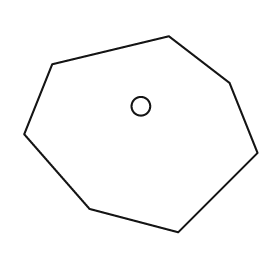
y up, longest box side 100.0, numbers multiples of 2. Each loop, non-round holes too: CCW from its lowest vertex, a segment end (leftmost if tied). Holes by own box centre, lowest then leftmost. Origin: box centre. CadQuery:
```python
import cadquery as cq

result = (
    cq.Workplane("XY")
    .moveTo(16.0, -42.0)
    .lineTo(50.0, -8.0)
    .lineTo(38.0, 22.0)
    .lineTo(12.0, 42.0)
    .lineTo(-38.0, 30.0)
    .lineTo(-50.0, 0.0)
    .lineTo(-22.0, -32.0)
    .close()
    .moveTo(0.0, 12.0)
    .circle(4.0)
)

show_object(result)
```